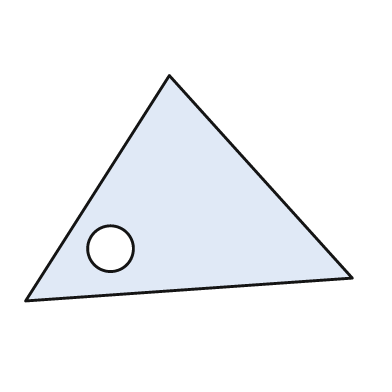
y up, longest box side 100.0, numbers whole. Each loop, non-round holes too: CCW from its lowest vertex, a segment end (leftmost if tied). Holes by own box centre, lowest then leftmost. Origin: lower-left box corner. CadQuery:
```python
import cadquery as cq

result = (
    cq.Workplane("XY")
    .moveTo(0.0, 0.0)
    .lineTo(100.0, 7.0)
    .lineTo(44.0, 69.0)
    .close()
    .moveTo(26.0, 16.0)
    .circle(7.0)
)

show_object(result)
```